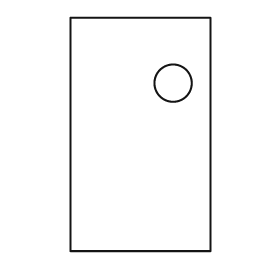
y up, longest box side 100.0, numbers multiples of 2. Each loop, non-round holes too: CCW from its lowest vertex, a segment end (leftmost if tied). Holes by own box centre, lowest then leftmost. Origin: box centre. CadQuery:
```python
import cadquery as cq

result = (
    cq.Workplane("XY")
    .moveTo(-30.0, -50.0)
    .lineTo(30.0, -50.0)
    .lineTo(30.0, 50.0)
    .lineTo(-30.0, 50.0)
    .close()
    .moveTo(14.0, 22.0)
    .circle(8.0)
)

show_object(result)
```